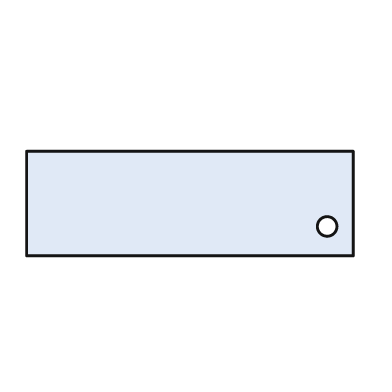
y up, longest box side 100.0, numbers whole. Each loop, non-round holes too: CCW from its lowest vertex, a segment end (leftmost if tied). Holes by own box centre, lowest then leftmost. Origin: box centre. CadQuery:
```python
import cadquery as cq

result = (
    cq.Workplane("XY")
    .moveTo(-50.0, -16.0)
    .lineTo(50.0, -16.0)
    .lineTo(50.0, 16.0)
    .lineTo(-50.0, 16.0)
    .close()
    .moveTo(42.0, -7.0)
    .circle(3.0)
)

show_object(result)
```